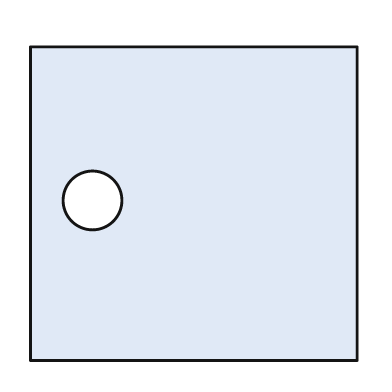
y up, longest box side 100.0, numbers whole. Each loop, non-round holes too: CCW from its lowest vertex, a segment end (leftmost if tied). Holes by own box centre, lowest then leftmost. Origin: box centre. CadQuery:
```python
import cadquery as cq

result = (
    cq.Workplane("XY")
    .moveTo(-50.0, -48.0)
    .lineTo(50.0, -48.0)
    .lineTo(50.0, 48.0)
    .lineTo(-50.0, 48.0)
    .close()
    .moveTo(-31.0, 1.0)
    .circle(9.0)
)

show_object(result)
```